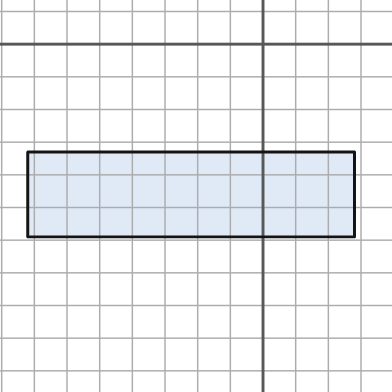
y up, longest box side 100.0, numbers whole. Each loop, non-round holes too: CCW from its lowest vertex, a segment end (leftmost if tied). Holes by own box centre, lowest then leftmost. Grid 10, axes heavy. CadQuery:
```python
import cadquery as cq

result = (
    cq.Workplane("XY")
    .moveTo(-72.0, -59.0)
    .lineTo(28.0, -59.0)
    .lineTo(28.0, -33.0)
    .lineTo(-72.0, -33.0)
    .close()
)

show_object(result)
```